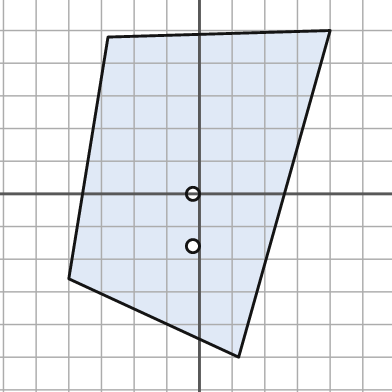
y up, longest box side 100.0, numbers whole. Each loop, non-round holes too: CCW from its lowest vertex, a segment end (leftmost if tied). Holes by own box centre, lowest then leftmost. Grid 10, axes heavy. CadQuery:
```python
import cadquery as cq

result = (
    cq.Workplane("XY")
    .moveTo(12.0, -50.0)
    .lineTo(40.0, 50.0)
    .lineTo(-28.0, 48.0)
    .lineTo(-40.0, -26.0)
    .close()
    .moveTo(-2.0, -16.0)
    .circle(2.0)
    .moveTo(-2.0, 0.0)
    .circle(2.0)
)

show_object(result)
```